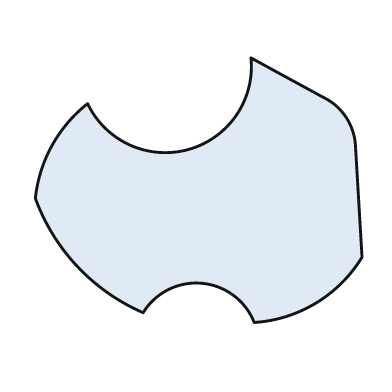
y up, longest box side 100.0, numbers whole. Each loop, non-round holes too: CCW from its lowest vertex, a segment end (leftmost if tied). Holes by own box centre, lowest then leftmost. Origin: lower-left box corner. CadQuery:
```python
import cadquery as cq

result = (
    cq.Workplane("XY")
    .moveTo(67.0, 0.0)
    .threePointArc((86.0, 6.0), (100.0, 20.0))
    .lineTo(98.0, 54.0)
    .threePointArc((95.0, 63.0), (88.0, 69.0))
    .lineTo(66.0, 81.0)
    .threePointArc((47.0, 53.0), (16.0, 67.0))
    .threePointArc((5.0, 54.0), (0.0, 38.0))
    .threePointArc((13.0, 17.0), (33.0, 3.0))
    .threePointArc((51.0, 12.0), (67.0, 0.0))
    .close()
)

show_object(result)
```